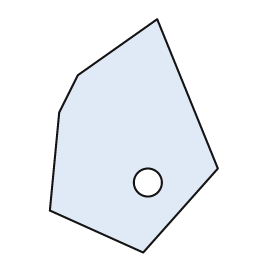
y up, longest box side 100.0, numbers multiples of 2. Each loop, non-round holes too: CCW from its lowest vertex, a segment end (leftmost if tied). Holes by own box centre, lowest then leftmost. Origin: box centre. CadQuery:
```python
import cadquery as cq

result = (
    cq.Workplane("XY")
    .moveTo(4.0, -50.0)
    .lineTo(36.0, -14.0)
    .lineTo(10.0, 50.0)
    .lineTo(-24.0, 26.0)
    .lineTo(-32.0, 10.0)
    .lineTo(-36.0, -32.0)
    .close()
    .moveTo(6.0, -20.0)
    .circle(6.0)
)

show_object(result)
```